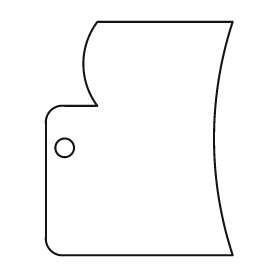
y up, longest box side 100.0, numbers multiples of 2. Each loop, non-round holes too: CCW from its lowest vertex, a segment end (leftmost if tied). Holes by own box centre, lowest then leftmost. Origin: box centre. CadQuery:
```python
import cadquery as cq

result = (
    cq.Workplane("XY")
    .moveTo(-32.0, -50.0)
    .lineTo(40.0, -50.0)
    .threePointArc((32.0, 0.0), (40.0, 50.0))
    .lineTo(-18.0, 50.0)
    .threePointArc((-24.0, 32.0), (-18.0, 14.0))
    .lineTo(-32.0, 14.0)
    .threePointArc((-38.0, 12.0), (-40.0, 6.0))
    .lineTo(-40.0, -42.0)
    .threePointArc((-38.0, -48.0), (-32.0, -50.0))
    .close()
    .moveTo(-32.0, -4.0)
    .circle(4.0)
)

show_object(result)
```